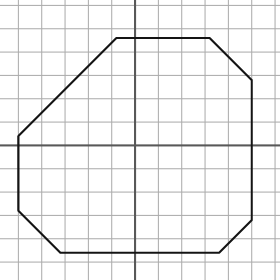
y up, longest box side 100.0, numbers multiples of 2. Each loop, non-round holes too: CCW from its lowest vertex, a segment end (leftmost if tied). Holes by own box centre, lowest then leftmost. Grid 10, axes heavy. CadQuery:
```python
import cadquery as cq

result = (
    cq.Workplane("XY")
    .moveTo(-32.0, -46.0)
    .lineTo(36.0, -46.0)
    .lineTo(50.0, -32.0)
    .lineTo(50.0, 28.0)
    .lineTo(32.0, 46.0)
    .lineTo(-8.0, 46.0)
    .lineTo(-50.0, 4.0)
    .lineTo(-50.0, -28.0)
    .close()
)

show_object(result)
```